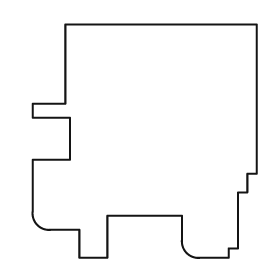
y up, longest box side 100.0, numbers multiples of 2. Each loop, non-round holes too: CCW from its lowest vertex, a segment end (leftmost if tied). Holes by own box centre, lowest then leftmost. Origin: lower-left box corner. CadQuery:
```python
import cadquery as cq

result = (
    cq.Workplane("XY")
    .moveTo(20.0, 0.0)
    .lineTo(32.0, 0.0)
    .lineTo(32.0, 18.0)
    .lineTo(64.0, 18.0)
    .lineTo(64.0, 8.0)
    .threePointArc((66.0, 2.0), (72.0, 0.0))
    .lineTo(84.0, 0.0)
    .lineTo(84.0, 4.0)
    .lineTo(88.0, 4.0)
    .lineTo(88.0, 28.0)
    .lineTo(92.0, 28.0)
    .lineTo(92.0, 36.0)
    .lineTo(96.0, 36.0)
    .lineTo(96.0, 100.0)
    .lineTo(14.0, 100.0)
    .lineTo(14.0, 66.0)
    .lineTo(0.0, 66.0)
    .lineTo(0.0, 60.0)
    .lineTo(16.0, 60.0)
    .lineTo(16.0, 42.0)
    .lineTo(0.0, 42.0)
    .lineTo(0.0, 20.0)
    .threePointArc((2.0, 14.0), (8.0, 12.0))
    .lineTo(20.0, 12.0)
    .close()
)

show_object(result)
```